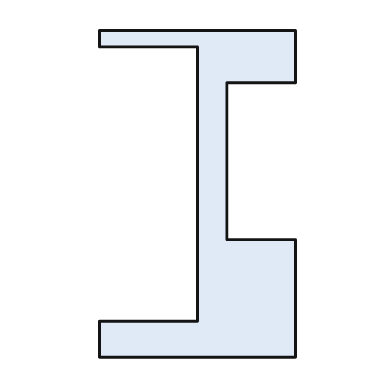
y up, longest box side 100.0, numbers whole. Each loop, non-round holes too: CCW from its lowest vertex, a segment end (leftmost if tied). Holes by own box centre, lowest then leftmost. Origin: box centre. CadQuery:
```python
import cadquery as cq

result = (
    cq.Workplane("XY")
    .moveTo(-30.0, -50.0)
    .lineTo(30.0, -50.0)
    .lineTo(30.0, -14.0)
    .lineTo(9.0, -14.0)
    .lineTo(9.0, 34.0)
    .lineTo(30.0, 34.0)
    .lineTo(30.0, 50.0)
    .lineTo(-30.0, 50.0)
    .lineTo(-30.0, 45.0)
    .lineTo(0.0, 45.0)
    .lineTo(0.0, -39.0)
    .lineTo(-30.0, -39.0)
    .close()
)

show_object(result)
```